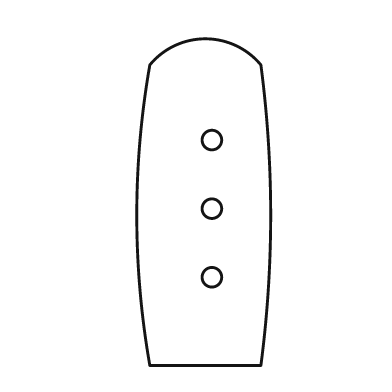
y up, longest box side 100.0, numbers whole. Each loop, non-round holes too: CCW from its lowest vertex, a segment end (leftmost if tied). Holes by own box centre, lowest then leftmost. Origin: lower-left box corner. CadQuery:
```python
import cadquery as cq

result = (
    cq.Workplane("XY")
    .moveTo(4.0, 0.0)
    .lineTo(38.0, 0.0)
    .threePointArc((41.0, 46.0), (38.0, 92.0))
    .threePointArc((21.0, 100.0), (4.0, 92.0))
    .threePointArc((0.0, 46.0), (4.0, 0.0))
    .close()
    .moveTo(23.0, 27.0)
    .circle(3.0)
    .moveTo(23.0, 48.0)
    .circle(3.0)
    .moveTo(23.0, 69.0)
    .circle(3.0)
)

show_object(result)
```